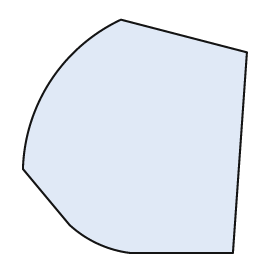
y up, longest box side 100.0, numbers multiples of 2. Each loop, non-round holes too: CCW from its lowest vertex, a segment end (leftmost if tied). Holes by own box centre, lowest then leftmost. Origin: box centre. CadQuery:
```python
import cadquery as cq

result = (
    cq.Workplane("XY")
    .moveTo(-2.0, -50.0)
    .lineTo(42.0, -50.0)
    .lineTo(48.0, 36.0)
    .lineTo(-6.0, 50.0)
    .threePointArc((-36.0, 24.0), (-48.0, -14.0))
    .lineTo(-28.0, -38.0)
    .threePointArc((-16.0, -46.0), (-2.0, -50.0))
    .close()
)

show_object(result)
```